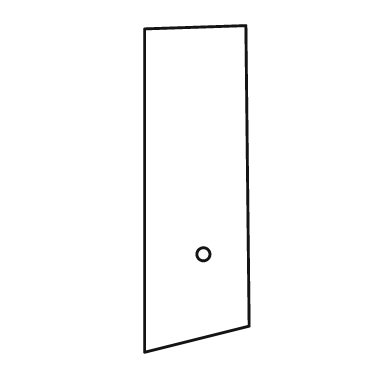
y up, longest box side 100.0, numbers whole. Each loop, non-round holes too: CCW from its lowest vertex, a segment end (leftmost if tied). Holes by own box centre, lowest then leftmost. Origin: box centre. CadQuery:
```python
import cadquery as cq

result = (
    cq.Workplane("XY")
    .moveTo(-16.0, -50.0)
    .lineTo(16.0, -42.0)
    .lineTo(15.0, 50.0)
    .lineTo(-16.0, 49.0)
    .close()
    .moveTo(2.0, -20.0)
    .circle(2.0)
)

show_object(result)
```